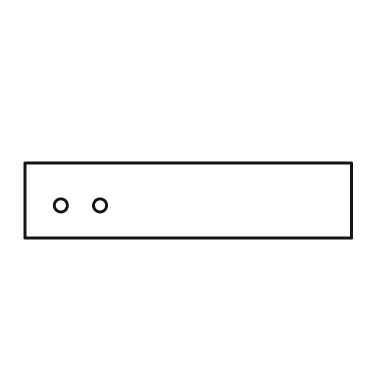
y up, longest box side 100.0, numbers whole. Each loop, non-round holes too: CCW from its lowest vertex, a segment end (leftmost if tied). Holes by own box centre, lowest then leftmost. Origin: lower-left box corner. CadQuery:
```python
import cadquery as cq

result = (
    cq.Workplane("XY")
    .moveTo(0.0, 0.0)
    .lineTo(100.0, 0.0)
    .lineTo(100.0, 23.0)
    .lineTo(0.0, 23.0)
    .close()
    .moveTo(11.0, 10.0)
    .circle(2.0)
    .moveTo(23.0, 10.0)
    .circle(2.0)
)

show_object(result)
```